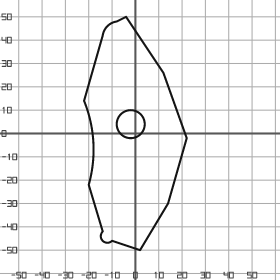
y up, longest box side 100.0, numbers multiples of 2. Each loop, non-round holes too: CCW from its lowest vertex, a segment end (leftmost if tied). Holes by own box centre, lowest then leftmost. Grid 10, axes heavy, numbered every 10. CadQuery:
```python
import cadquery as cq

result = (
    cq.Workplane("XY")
    .moveTo(2.0, -50.0)
    .lineTo(14.0, -30.0)
    .lineTo(22.0, -2.0)
    .lineTo(12.0, 26.0)
    .lineTo(-4.0, 50.0)
    .lineTo(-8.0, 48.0)
    .threePointArc((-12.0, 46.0), (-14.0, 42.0))
    .lineTo(-22.0, 14.0)
    .threePointArc((-18.0, -4.0), (-20.0, -22.0))
    .lineTo(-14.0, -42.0)
    .threePointArc((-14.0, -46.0), (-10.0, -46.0))
    .close()
    .moveTo(-2.0, 4.0)
    .circle(6.0)
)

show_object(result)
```